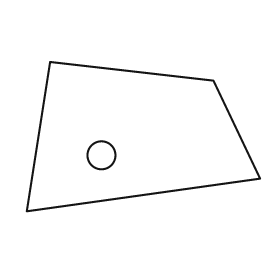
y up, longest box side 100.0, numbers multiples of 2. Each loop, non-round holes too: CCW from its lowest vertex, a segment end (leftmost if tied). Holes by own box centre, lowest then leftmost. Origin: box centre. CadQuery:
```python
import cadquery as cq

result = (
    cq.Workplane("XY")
    .moveTo(-50.0, -32.0)
    .lineTo(50.0, -18.0)
    .lineTo(30.0, 24.0)
    .lineTo(-40.0, 32.0)
    .close()
    .moveTo(-18.0, -8.0)
    .circle(6.0)
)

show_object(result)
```